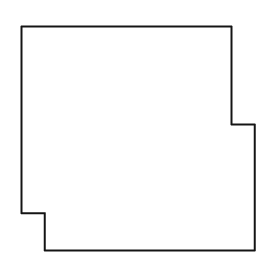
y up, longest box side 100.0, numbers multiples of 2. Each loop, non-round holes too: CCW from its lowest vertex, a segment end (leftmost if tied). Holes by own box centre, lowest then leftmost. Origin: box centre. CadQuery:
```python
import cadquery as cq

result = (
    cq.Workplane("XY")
    .moveTo(-40.0, -48.0)
    .lineTo(50.0, -48.0)
    .lineTo(50.0, 6.0)
    .lineTo(40.0, 6.0)
    .lineTo(40.0, 48.0)
    .lineTo(-50.0, 48.0)
    .lineTo(-50.0, -32.0)
    .lineTo(-40.0, -32.0)
    .close()
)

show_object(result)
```